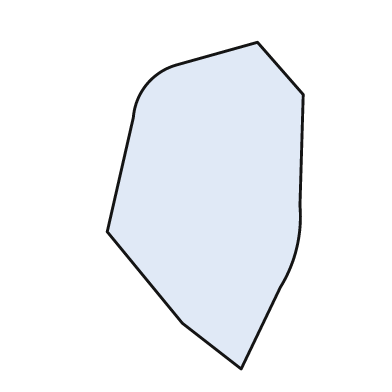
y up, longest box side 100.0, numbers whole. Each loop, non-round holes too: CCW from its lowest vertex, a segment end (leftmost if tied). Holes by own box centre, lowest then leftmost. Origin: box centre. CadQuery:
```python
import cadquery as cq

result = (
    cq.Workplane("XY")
    .moveTo(11.0, -50.0)
    .lineTo(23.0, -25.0)
    .threePointArc((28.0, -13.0), (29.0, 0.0))
    .lineTo(30.0, 34.0)
    .lineTo(16.0, 50.0)
    .lineTo(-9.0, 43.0)
    .threePointArc((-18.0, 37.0), (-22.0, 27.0))
    .lineTo(-30.0, -8.0)
    .lineTo(-7.0, -36.0)
    .close()
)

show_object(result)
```